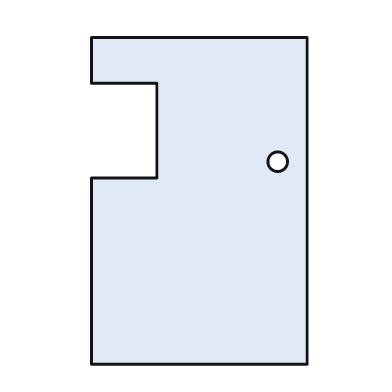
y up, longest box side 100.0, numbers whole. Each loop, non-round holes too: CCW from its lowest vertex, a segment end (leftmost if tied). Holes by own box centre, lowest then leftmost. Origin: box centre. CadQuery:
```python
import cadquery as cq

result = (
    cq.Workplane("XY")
    .moveTo(-33.0, -50.0)
    .lineTo(33.0, -50.0)
    .lineTo(33.0, 50.0)
    .lineTo(-33.0, 50.0)
    .lineTo(-33.0, 36.0)
    .lineTo(-13.0, 36.0)
    .lineTo(-13.0, 7.0)
    .lineTo(-33.0, 7.0)
    .close()
    .moveTo(24.0, 12.0)
    .circle(3.0)
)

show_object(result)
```